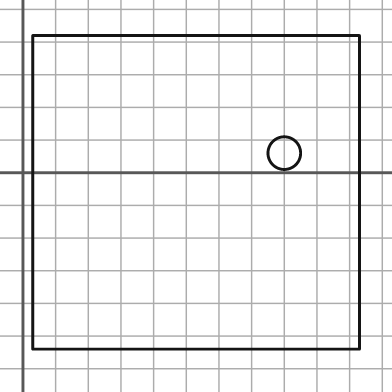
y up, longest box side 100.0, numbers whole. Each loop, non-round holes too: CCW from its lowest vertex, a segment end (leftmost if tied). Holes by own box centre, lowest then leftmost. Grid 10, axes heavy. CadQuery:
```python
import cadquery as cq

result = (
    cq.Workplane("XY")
    .moveTo(3.0, -54.0)
    .lineTo(103.0, -54.0)
    .lineTo(103.0, 42.0)
    .lineTo(3.0, 42.0)
    .close()
    .moveTo(80.0, 6.0)
    .circle(5.0)
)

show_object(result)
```